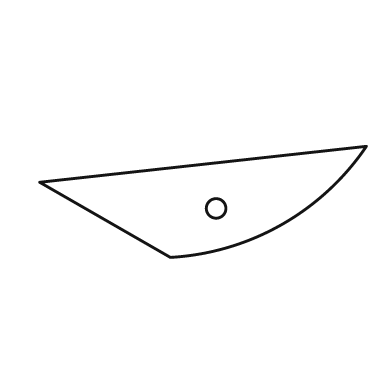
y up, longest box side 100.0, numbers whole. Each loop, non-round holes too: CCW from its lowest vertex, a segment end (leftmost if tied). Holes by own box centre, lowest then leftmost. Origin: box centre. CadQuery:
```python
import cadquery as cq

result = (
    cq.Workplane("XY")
    .moveTo(-10.0, -17.0)
    .threePointArc((24.0, -7.0), (50.0, 17.0))
    .lineTo(-50.0, 6.0)
    .close()
    .moveTo(4.0, -2.0)
    .circle(3.0)
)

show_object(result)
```